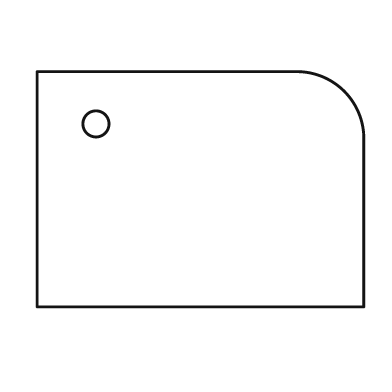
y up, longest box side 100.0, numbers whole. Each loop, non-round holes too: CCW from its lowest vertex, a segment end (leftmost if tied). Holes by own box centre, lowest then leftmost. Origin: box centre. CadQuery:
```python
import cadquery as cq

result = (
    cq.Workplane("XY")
    .moveTo(-50.0, -36.0)
    .lineTo(50.0, -36.0)
    .lineTo(50.0, 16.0)
    .threePointArc((44.0, 30.0), (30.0, 36.0))
    .lineTo(-50.0, 36.0)
    .close()
    .moveTo(-32.0, 20.0)
    .circle(4.0)
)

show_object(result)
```